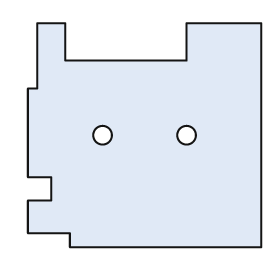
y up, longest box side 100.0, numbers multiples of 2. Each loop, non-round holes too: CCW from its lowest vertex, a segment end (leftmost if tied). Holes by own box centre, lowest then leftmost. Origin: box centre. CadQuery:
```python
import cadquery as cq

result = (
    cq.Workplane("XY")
    .moveTo(-32.0, -48.0)
    .lineTo(50.0, -48.0)
    .lineTo(50.0, 48.0)
    .lineTo(18.0, 48.0)
    .lineTo(18.0, 32.0)
    .lineTo(-34.0, 32.0)
    .lineTo(-34.0, 48.0)
    .lineTo(-46.0, 48.0)
    .lineTo(-46.0, 20.0)
    .lineTo(-50.0, 20.0)
    .lineTo(-50.0, -18.0)
    .lineTo(-40.0, -18.0)
    .lineTo(-40.0, -28.0)
    .lineTo(-50.0, -28.0)
    .lineTo(-50.0, -42.0)
    .lineTo(-32.0, -42.0)
    .close()
    .moveTo(-18.0, 0.0)
    .circle(4.0)
    .moveTo(18.0, 0.0)
    .circle(4.0)
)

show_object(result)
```